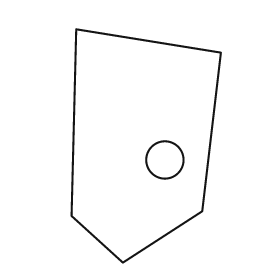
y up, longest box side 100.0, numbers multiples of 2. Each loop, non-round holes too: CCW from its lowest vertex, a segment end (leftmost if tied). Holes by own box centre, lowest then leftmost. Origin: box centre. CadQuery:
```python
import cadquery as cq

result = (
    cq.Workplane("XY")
    .moveTo(-10.0, -50.0)
    .lineTo(24.0, -28.0)
    .lineTo(32.0, 40.0)
    .lineTo(-30.0, 50.0)
    .lineTo(-32.0, -30.0)
    .close()
    .moveTo(8.0, -6.0)
    .circle(8.0)
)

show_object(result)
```